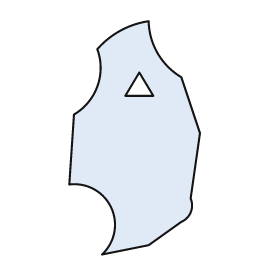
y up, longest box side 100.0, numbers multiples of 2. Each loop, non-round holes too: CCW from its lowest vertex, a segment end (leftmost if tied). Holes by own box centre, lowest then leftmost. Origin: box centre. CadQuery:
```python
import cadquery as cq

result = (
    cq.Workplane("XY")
    .moveTo(-14.0, -50.0)
    .lineTo(6.0, -46.0)
    .lineTo(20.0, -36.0)
    .threePointArc((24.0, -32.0), (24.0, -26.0))
    .lineTo(28.0, 2.0)
    .lineTo(20.0, 26.0)
    .threePointArc((10.0, 36.0), (6.0, 50.0))
    .threePointArc((-6.0, 46.0), (-16.0, 38.0))
    .threePointArc((-16.0, 22.0), (-26.0, 10.0))
    .lineTo(-28.0, -20.0)
    .threePointArc((-10.0, -30.0), (-14.0, -50.0))
    .close()
    .moveTo(-4.0, 18.0)
    .lineTo(8.0, 18.0)
    .lineTo(2.0, 28.0)
    .close()
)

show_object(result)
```